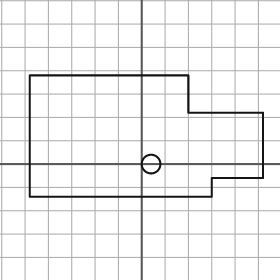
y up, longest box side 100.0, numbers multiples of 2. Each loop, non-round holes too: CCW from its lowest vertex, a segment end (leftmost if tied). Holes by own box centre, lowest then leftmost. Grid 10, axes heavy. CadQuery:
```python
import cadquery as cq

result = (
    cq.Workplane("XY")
    .moveTo(-48.0, -14.0)
    .lineTo(30.0, -14.0)
    .lineTo(30.0, -6.0)
    .lineTo(52.0, -6.0)
    .lineTo(52.0, 22.0)
    .lineTo(20.0, 22.0)
    .lineTo(20.0, 38.0)
    .lineTo(-48.0, 38.0)
    .close()
    .moveTo(4.0, 0.0)
    .circle(4.0)
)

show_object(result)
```